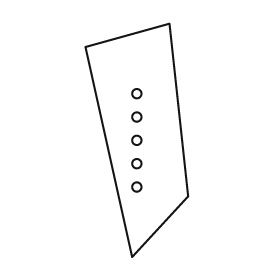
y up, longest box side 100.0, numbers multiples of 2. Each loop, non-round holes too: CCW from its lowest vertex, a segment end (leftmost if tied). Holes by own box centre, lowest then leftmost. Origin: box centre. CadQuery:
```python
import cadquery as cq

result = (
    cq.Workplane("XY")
    .moveTo(-2.0, -50.0)
    .lineTo(22.0, -24.0)
    .lineTo(14.0, 50.0)
    .lineTo(-22.0, 40.0)
    .close()
    .moveTo(0.0, -20.0)
    .circle(2.0)
    .moveTo(0.0, -10.0)
    .circle(2.0)
    .moveTo(0.0, 0.0)
    .circle(2.0)
    .moveTo(0.0, 10.0)
    .circle(2.0)
    .moveTo(0.0, 20.0)
    .circle(2.0)
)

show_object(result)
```